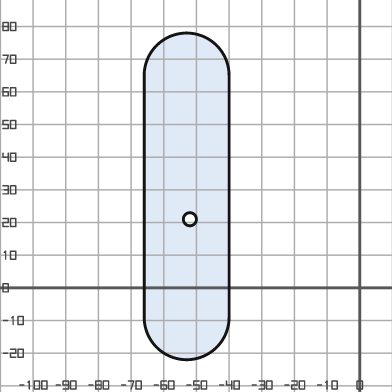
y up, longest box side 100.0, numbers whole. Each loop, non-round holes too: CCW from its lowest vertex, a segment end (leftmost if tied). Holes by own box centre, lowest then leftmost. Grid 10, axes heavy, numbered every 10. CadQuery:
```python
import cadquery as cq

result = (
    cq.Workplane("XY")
    .moveTo(-66.0, -9.0)
    .threePointArc((-53.0, -22.0), (-40.0, -9.0))
    .lineTo(-40.0, 65.0)
    .threePointArc((-53.0, 78.0), (-66.0, 65.0))
    .close()
    .moveTo(-52.0, 21.0)
    .circle(2.0)
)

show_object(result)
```